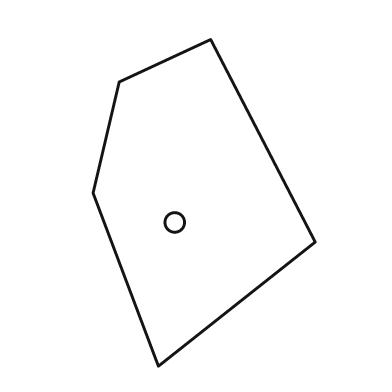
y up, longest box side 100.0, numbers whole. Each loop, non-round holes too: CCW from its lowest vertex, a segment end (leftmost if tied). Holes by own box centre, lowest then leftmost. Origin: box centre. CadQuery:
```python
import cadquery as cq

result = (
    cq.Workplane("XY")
    .moveTo(-14.0, -50.0)
    .lineTo(34.0, -12.0)
    .lineTo(2.0, 50.0)
    .lineTo(-26.0, 37.0)
    .lineTo(-34.0, 3.0)
    .close()
    .moveTo(-9.0, -6.0)
    .circle(3.0)
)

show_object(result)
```